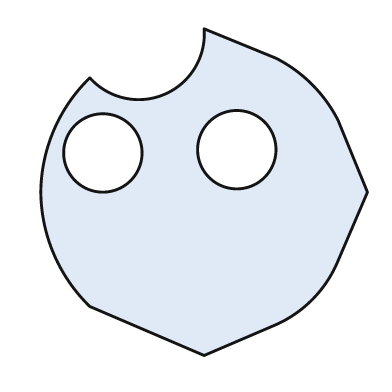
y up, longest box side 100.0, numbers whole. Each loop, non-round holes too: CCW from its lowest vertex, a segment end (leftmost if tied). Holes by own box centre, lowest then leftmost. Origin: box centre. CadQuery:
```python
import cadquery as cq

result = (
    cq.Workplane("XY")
    .moveTo(0.0, -50.0)
    .lineTo(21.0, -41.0)
    .threePointArc((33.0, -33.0), (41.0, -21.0))
    .lineTo(50.0, 0.0)
    .lineTo(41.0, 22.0)
    .threePointArc((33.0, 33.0), (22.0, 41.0))
    .lineTo(0.0, 50.0)
    .threePointArc((-12.0, 30.0), (-35.0, 35.0))
    .threePointArc((-46.0, 19.0), (-50.0, 0.0))
    .threePointArc((-46.0, -19.0), (-35.0, -35.0))
    .close()
    .moveTo(-31.0, 12.0)
    .circle(12.0)
    .moveTo(10.0, 13.0)
    .circle(12.0)
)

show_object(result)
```